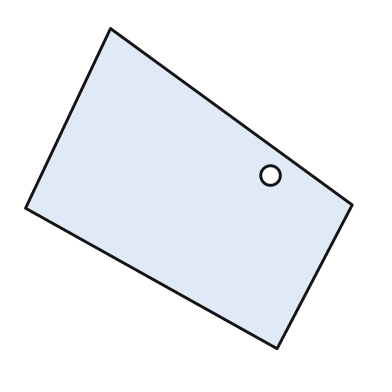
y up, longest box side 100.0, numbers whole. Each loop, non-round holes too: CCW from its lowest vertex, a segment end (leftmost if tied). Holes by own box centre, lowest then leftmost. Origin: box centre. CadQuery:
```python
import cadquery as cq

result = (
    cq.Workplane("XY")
    .moveTo(27.0, -49.0)
    .lineTo(50.0, -5.0)
    .lineTo(-24.0, 49.0)
    .lineTo(-50.0, -6.0)
    .close()
    .moveTo(25.0, 4.0)
    .circle(3.0)
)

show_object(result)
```